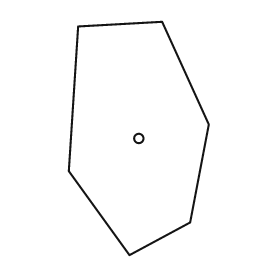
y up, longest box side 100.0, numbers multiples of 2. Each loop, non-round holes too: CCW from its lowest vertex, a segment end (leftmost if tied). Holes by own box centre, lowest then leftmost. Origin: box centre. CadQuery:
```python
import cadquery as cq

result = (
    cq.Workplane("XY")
    .moveTo(-4.0, -50.0)
    .lineTo(22.0, -36.0)
    .lineTo(30.0, 6.0)
    .lineTo(10.0, 50.0)
    .lineTo(-26.0, 48.0)
    .lineTo(-30.0, -14.0)
    .close()
    .moveTo(0.0, 0.0)
    .circle(2.0)
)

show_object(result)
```